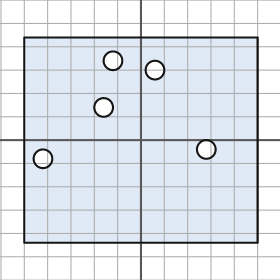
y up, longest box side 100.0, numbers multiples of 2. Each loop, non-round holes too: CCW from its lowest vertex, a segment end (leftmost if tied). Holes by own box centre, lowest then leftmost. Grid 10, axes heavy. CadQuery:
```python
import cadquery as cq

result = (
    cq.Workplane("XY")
    .moveTo(-50.0, -44.0)
    .lineTo(50.0, -44.0)
    .lineTo(50.0, 44.0)
    .lineTo(-50.0, 44.0)
    .close()
    .moveTo(-42.0, -8.0)
    .circle(4.0)
    .moveTo(28.0, -4.0)
    .circle(4.0)
    .moveTo(-16.0, 14.0)
    .circle(4.0)
    .moveTo(6.0, 30.0)
    .circle(4.0)
    .moveTo(-12.0, 34.0)
    .circle(4.0)
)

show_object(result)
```